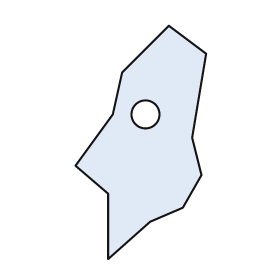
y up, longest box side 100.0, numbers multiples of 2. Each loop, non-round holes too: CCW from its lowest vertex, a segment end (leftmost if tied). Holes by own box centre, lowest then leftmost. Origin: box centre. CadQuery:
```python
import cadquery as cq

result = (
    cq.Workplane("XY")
    .moveTo(-14.0, -50.0)
    .lineTo(4.0, -34.0)
    .lineTo(18.0, -28.0)
    .lineTo(26.0, -14.0)
    .lineTo(22.0, 2.0)
    .lineTo(28.0, 38.0)
    .lineTo(12.0, 50.0)
    .lineTo(-8.0, 30.0)
    .lineTo(-12.0, 12.0)
    .lineTo(-28.0, -10.0)
    .lineTo(-14.0, -22.0)
    .close()
    .moveTo(2.0, 12.0)
    .circle(6.0)
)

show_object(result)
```